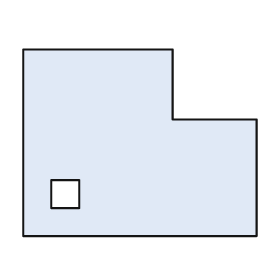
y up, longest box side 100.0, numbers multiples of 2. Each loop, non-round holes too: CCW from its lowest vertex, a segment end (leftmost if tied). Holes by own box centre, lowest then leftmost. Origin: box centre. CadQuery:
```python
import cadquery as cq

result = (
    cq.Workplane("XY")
    .moveTo(-50.0, -40.0)
    .lineTo(50.0, -40.0)
    .lineTo(50.0, 10.0)
    .lineTo(14.0, 10.0)
    .lineTo(14.0, 40.0)
    .lineTo(-50.0, 40.0)
    .close()
    .moveTo(-38.0, -28.0)
    .lineTo(-26.0, -28.0)
    .lineTo(-26.0, -16.0)
    .lineTo(-38.0, -16.0)
    .close()
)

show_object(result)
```